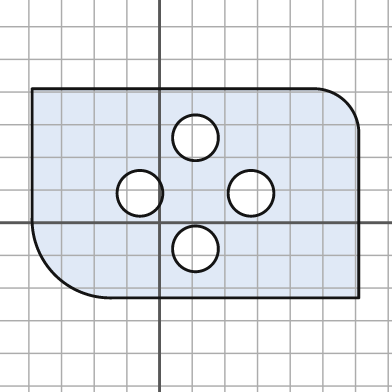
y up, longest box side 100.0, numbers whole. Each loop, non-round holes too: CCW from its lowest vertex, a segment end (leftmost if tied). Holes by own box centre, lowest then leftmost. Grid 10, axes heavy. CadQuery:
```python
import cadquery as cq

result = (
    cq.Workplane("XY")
    .moveTo(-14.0, -23.0)
    .lineTo(61.0, -23.0)
    .lineTo(61.0, 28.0)
    .threePointArc((57.0, 37.0), (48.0, 41.0))
    .lineTo(-39.0, 41.0)
    .lineTo(-39.0, 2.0)
    .threePointArc((-32.0, -16.0), (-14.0, -23.0))
    .close()
    .moveTo(11.0, -8.0)
    .circle(7.0)
    .moveTo(-6.0, 9.0)
    .circle(7.0)
    .moveTo(28.0, 9.0)
    .circle(7.0)
    .moveTo(11.0, 26.0)
    .circle(7.0)
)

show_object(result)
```